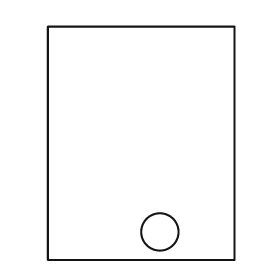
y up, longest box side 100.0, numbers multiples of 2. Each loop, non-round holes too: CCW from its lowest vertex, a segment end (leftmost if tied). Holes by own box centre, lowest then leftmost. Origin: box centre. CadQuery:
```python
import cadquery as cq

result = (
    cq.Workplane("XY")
    .moveTo(-40.0, -50.0)
    .lineTo(40.0, -50.0)
    .lineTo(40.0, 50.0)
    .lineTo(-40.0, 50.0)
    .close()
    .moveTo(8.0, -38.0)
    .circle(8.0)
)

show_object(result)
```